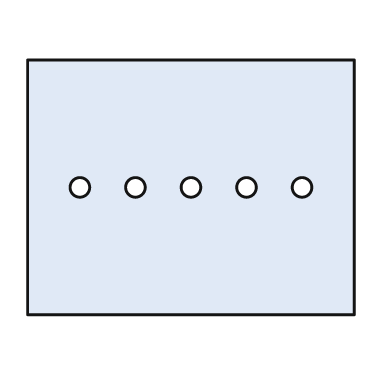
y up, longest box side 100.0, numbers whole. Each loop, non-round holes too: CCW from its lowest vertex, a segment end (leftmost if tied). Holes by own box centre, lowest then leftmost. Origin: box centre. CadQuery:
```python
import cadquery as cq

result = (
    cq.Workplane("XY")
    .moveTo(-50.0, -39.0)
    .lineTo(50.0, -39.0)
    .lineTo(50.0, 39.0)
    .lineTo(-50.0, 39.0)
    .close()
    .moveTo(-34.0, 0.0)
    .circle(3.0)
    .moveTo(-17.0, 0.0)
    .circle(3.0)
    .moveTo(0.0, 0.0)
    .circle(3.0)
    .moveTo(17.0, 0.0)
    .circle(3.0)
    .moveTo(34.0, 0.0)
    .circle(3.0)
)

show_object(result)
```